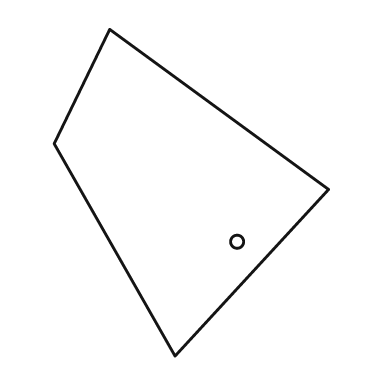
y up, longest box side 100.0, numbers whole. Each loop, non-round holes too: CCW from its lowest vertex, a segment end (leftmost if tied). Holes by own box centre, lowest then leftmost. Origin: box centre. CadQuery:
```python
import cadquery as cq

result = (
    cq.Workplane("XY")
    .moveTo(-5.0, -50.0)
    .lineTo(42.0, 1.0)
    .lineTo(-25.0, 50.0)
    .lineTo(-42.0, 15.0)
    .close()
    .moveTo(14.0, -15.0)
    .circle(2.0)
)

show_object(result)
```